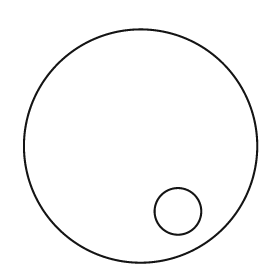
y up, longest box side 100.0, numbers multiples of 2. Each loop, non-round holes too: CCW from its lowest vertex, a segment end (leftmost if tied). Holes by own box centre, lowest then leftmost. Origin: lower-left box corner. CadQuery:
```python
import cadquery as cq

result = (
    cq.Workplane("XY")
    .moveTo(50.0, 50.0)
    .circle(50.0)
    .moveTo(66.0, 22.0)
    .circle(10.0)
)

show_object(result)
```